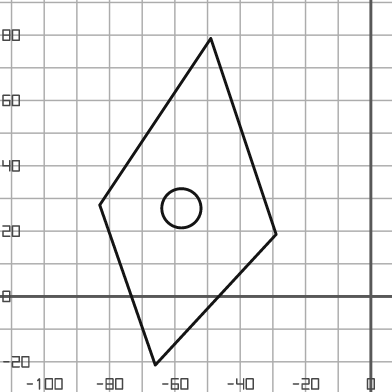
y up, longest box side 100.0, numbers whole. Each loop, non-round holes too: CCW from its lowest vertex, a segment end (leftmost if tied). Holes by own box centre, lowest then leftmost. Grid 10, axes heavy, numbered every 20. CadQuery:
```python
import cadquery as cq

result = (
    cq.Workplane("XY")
    .moveTo(-66.0, -21.0)
    .lineTo(-29.0, 19.0)
    .lineTo(-49.0, 79.0)
    .lineTo(-83.0, 28.0)
    .close()
    .moveTo(-58.0, 27.0)
    .circle(6.0)
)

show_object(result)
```